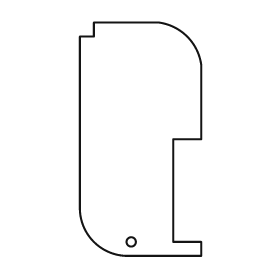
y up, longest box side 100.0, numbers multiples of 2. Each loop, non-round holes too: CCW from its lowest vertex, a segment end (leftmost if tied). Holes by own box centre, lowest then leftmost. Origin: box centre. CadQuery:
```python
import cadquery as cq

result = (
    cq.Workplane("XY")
    .moveTo(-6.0, -50.0)
    .lineTo(26.0, -50.0)
    .lineTo(26.0, -44.0)
    .lineTo(14.0, -44.0)
    .lineTo(14.0, 0.0)
    .lineTo(26.0, 0.0)
    .lineTo(26.0, 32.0)
    .threePointArc((20.0, 44.0), (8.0, 50.0))
    .lineTo(-20.0, 50.0)
    .lineTo(-20.0, 44.0)
    .lineTo(-26.0, 44.0)
    .lineTo(-26.0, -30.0)
    .threePointArc((-20.0, -44.0), (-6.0, -50.0))
    .close()
    .moveTo(-4.0, -44.0)
    .circle(2.0)
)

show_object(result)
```